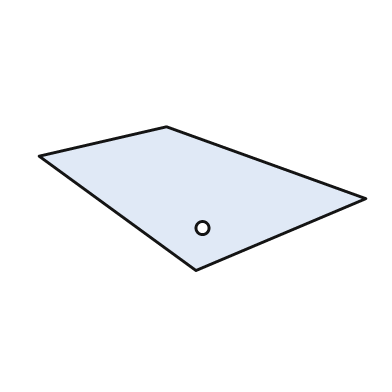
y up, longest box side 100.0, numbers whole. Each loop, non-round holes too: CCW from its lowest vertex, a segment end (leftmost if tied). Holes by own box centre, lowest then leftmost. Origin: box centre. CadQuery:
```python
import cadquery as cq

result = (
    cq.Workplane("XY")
    .moveTo(-2.0, -22.0)
    .lineTo(50.0, 0.0)
    .lineTo(-11.0, 22.0)
    .lineTo(-50.0, 13.0)
    .close()
    .moveTo(0.0, -9.0)
    .circle(2.0)
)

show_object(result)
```